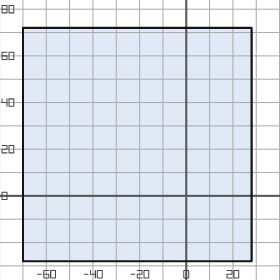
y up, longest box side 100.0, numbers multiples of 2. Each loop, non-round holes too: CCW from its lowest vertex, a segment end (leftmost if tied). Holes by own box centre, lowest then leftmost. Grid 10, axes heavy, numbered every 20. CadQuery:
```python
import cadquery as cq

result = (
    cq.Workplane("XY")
    .moveTo(-70.0, -28.0)
    .lineTo(28.0, -28.0)
    .lineTo(28.0, 72.0)
    .lineTo(-70.0, 72.0)
    .close()
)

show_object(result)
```